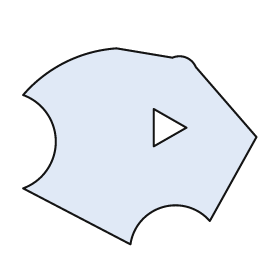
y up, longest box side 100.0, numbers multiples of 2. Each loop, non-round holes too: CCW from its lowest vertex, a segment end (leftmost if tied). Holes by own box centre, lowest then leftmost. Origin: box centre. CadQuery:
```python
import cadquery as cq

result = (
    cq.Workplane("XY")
    .moveTo(-4.0, -42.0)
    .threePointArc((10.0, -26.0), (30.0, -32.0))
    .lineTo(50.0, 4.0)
    .lineTo(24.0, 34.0)
    .threePointArc((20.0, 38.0), (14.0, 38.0))
    .lineTo(-10.0, 42.0)
    .threePointArc((-32.0, 36.0), (-50.0, 22.0))
    .threePointArc((-36.0, 2.0), (-50.0, -18.0))
    .close()
    .moveTo(6.0, 0.0)
    .lineTo(20.0, 8.0)
    .lineTo(6.0, 16.0)
    .close()
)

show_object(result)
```